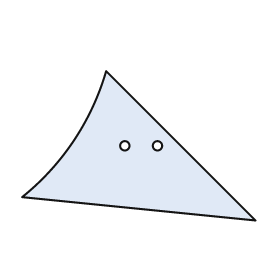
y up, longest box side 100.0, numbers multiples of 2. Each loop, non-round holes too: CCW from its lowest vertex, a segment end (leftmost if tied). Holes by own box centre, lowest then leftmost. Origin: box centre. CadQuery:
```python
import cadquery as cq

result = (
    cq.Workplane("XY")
    .moveTo(50.0, -32.0)
    .lineTo(-14.0, 32.0)
    .threePointArc((-28.0, 2.0), (-50.0, -22.0))
    .close()
    .moveTo(-6.0, 0.0)
    .circle(2.0)
    .moveTo(8.0, 0.0)
    .circle(2.0)
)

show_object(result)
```